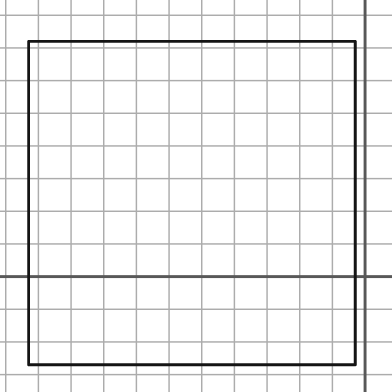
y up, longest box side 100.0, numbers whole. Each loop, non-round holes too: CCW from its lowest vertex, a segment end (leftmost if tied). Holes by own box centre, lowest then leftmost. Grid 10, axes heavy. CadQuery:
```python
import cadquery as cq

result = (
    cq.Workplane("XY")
    .moveTo(-103.0, -27.0)
    .lineTo(-3.0, -27.0)
    .lineTo(-3.0, 72.0)
    .lineTo(-103.0, 72.0)
    .close()
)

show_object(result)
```